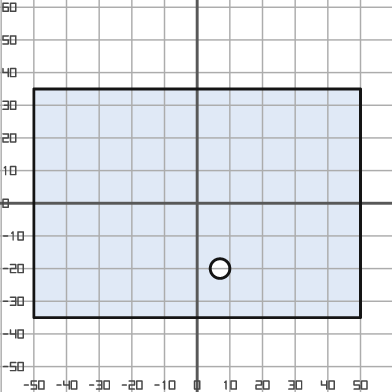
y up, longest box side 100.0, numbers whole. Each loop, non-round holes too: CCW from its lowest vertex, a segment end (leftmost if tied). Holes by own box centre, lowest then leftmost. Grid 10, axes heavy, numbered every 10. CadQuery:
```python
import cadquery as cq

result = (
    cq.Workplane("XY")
    .moveTo(-50.0, -35.0)
    .lineTo(50.0, -35.0)
    .lineTo(50.0, 35.0)
    .lineTo(-50.0, 35.0)
    .close()
    .moveTo(7.0, -20.0)
    .circle(3.0)
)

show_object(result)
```